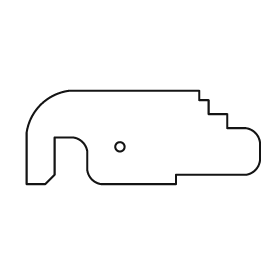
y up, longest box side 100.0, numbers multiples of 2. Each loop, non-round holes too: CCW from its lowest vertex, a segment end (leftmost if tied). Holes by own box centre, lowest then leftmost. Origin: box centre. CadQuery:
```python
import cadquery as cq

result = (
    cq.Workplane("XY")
    .moveTo(-50.0, -20.0)
    .lineTo(-42.0, -20.0)
    .lineTo(-38.0, -16.0)
    .lineTo(-38.0, 0.0)
    .lineTo(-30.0, 0.0)
    .threePointArc((-26.0, -2.0), (-24.0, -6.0))
    .lineTo(-24.0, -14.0)
    .threePointArc((-22.0, -18.0), (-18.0, -20.0))
    .lineTo(14.0, -20.0)
    .lineTo(14.0, -16.0)
    .lineTo(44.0, -16.0)
    .threePointArc((48.0, -14.0), (50.0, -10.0))
    .lineTo(50.0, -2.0)
    .threePointArc((48.0, 2.0), (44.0, 4.0))
    .lineTo(36.0, 4.0)
    .lineTo(36.0, 10.0)
    .lineTo(28.0, 10.0)
    .lineTo(28.0, 16.0)
    .lineTo(24.0, 16.0)
    .lineTo(24.0, 20.0)
    .lineTo(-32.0, 20.0)
    .threePointArc((-44.0, 14.0), (-50.0, 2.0))
    .close()
    .moveTo(-10.0, -4.0)
    .circle(2.0)
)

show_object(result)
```